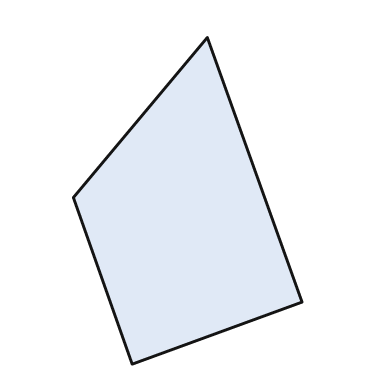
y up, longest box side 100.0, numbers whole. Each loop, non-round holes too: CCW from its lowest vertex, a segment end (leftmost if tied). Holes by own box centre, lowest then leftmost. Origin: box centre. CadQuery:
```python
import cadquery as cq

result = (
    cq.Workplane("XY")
    .moveTo(-17.0, -50.0)
    .lineTo(35.0, -31.0)
    .lineTo(6.0, 50.0)
    .lineTo(-35.0, 1.0)
    .close()
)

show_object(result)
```